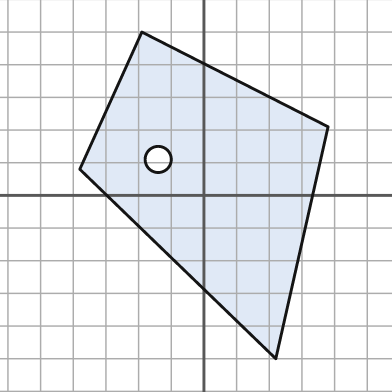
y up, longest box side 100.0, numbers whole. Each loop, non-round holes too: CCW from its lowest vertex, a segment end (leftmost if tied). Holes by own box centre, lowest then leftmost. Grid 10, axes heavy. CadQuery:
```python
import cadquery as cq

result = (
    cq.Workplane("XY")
    .moveTo(22.0, -50.0)
    .lineTo(38.0, 21.0)
    .lineTo(-19.0, 50.0)
    .lineTo(-38.0, 8.0)
    .close()
    .moveTo(-14.0, 11.0)
    .circle(4.0)
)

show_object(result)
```